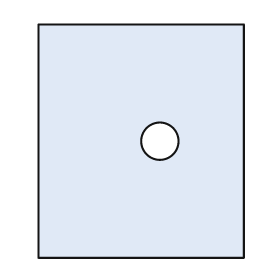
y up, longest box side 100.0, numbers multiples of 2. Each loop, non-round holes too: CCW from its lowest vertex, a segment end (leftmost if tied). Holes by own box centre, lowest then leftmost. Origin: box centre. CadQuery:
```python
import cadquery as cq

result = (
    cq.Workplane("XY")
    .moveTo(-44.0, -50.0)
    .lineTo(44.0, -50.0)
    .lineTo(44.0, 50.0)
    .lineTo(-44.0, 50.0)
    .close()
    .moveTo(8.0, 0.0)
    .circle(8.0)
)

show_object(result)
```